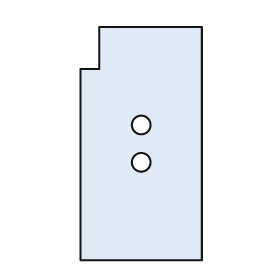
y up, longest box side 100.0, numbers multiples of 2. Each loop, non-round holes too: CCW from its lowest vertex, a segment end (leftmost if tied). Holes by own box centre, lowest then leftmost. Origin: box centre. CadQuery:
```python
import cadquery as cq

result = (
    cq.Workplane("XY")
    .moveTo(-26.0, -50.0)
    .lineTo(26.0, -50.0)
    .lineTo(26.0, 50.0)
    .lineTo(-18.0, 50.0)
    .lineTo(-18.0, 32.0)
    .lineTo(-26.0, 32.0)
    .close()
    .moveTo(0.0, -8.0)
    .circle(4.0)
    .moveTo(0.0, 8.0)
    .circle(4.0)
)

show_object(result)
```